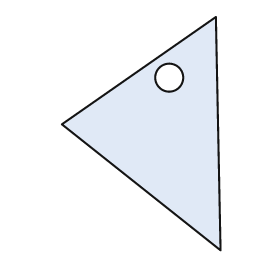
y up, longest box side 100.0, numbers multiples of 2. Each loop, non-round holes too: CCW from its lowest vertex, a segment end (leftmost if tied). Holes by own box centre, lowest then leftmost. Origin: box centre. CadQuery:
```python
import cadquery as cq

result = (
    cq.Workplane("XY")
    .moveTo(34.0, -50.0)
    .lineTo(32.0, 50.0)
    .lineTo(-34.0, 4.0)
    .close()
    .moveTo(12.0, 24.0)
    .circle(6.0)
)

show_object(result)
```